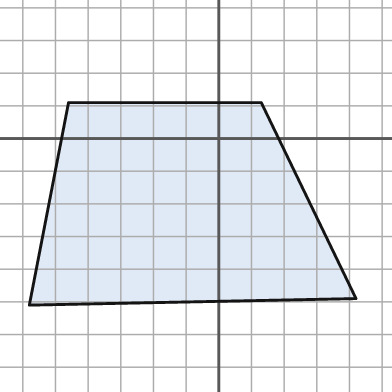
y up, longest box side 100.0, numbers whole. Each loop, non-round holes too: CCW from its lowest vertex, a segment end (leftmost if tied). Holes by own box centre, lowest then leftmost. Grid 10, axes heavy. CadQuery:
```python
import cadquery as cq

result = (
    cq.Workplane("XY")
    .moveTo(-58.0, -51.0)
    .lineTo(42.0, -49.0)
    .lineTo(13.0, 11.0)
    .lineTo(-46.0, 11.0)
    .close()
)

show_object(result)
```